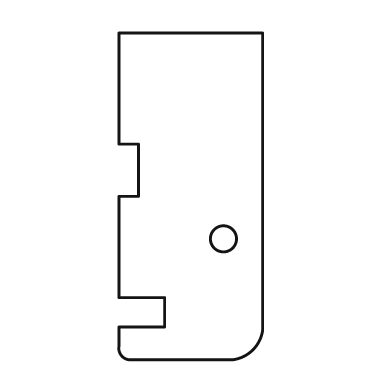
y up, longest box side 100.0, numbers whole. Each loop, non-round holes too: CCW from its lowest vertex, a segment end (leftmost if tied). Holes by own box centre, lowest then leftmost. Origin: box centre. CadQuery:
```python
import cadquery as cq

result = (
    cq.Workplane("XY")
    .moveTo(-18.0, -50.0)
    .lineTo(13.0, -50.0)
    .threePointArc((19.0, -47.0), (22.0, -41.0))
    .lineTo(22.0, 50.0)
    .lineTo(-22.0, 50.0)
    .lineTo(-22.0, 16.0)
    .lineTo(-16.0, 16.0)
    .lineTo(-16.0, 0.0)
    .lineTo(-22.0, 0.0)
    .lineTo(-22.0, -31.0)
    .lineTo(-8.0, -31.0)
    .lineTo(-8.0, -40.0)
    .lineTo(-22.0, -40.0)
    .lineTo(-22.0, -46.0)
    .threePointArc((-21.0, -49.0), (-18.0, -50.0))
    .close()
    .moveTo(10.0, -13.0)
    .circle(4.0)
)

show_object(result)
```